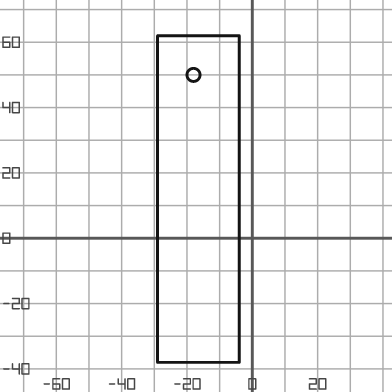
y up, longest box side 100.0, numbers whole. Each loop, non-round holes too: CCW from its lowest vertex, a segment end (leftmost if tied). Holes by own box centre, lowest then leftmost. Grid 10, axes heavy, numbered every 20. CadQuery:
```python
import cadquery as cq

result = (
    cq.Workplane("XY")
    .moveTo(-29.0, -38.0)
    .lineTo(-4.0, -38.0)
    .lineTo(-4.0, 62.0)
    .lineTo(-29.0, 62.0)
    .close()
    .moveTo(-18.0, 50.0)
    .circle(2.0)
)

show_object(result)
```